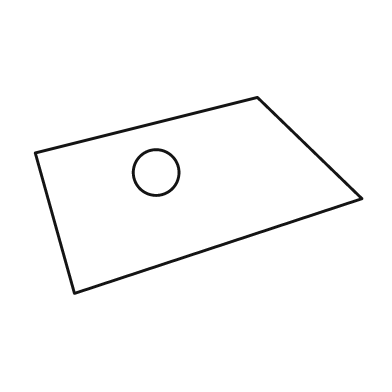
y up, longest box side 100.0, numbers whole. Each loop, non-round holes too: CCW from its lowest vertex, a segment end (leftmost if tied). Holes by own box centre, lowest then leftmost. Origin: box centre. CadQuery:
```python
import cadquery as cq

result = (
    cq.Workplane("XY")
    .moveTo(-38.0, -30.0)
    .lineTo(50.0, -1.0)
    .lineTo(18.0, 30.0)
    .lineTo(-50.0, 13.0)
    .close()
    .moveTo(-13.0, 7.0)
    .circle(7.0)
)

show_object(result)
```